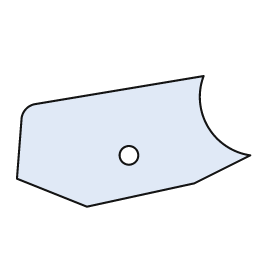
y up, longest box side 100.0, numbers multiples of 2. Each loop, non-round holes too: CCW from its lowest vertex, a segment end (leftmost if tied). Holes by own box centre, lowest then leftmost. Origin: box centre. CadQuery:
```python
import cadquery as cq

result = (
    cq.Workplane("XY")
    .moveTo(-20.0, -28.0)
    .lineTo(26.0, -18.0)
    .lineTo(50.0, -6.0)
    .threePointArc((32.0, 6.0), (30.0, 28.0))
    .lineTo(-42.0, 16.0)
    .threePointArc((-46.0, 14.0), (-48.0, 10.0))
    .lineTo(-50.0, -16.0)
    .close()
    .moveTo(-2.0, -6.0)
    .circle(4.0)
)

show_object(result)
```